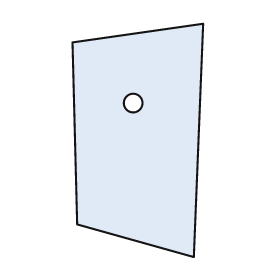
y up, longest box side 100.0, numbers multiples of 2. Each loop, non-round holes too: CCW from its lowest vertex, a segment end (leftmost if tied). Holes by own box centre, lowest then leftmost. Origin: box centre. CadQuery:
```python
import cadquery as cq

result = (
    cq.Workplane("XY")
    .moveTo(24.0, -50.0)
    .lineTo(28.0, 50.0)
    .lineTo(-28.0, 42.0)
    .lineTo(-26.0, -36.0)
    .close()
    .moveTo(-2.0, 16.0)
    .circle(4.0)
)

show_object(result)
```